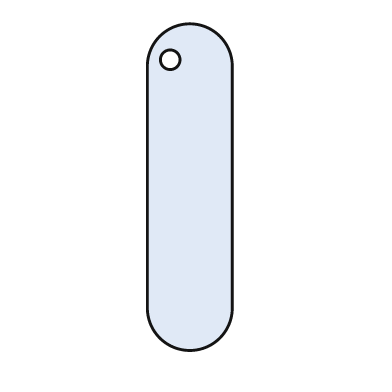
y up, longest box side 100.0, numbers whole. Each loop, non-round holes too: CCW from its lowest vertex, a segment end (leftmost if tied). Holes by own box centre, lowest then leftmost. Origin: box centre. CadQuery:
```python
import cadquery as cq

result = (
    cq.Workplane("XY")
    .moveTo(-13.0, -37.0)
    .threePointArc((0.0, -50.0), (13.0, -37.0))
    .lineTo(13.0, 37.0)
    .threePointArc((0.0, 50.0), (-13.0, 37.0))
    .close()
    .moveTo(-6.0, 39.0)
    .circle(3.0)
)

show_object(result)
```